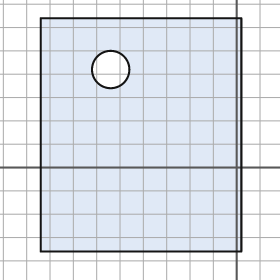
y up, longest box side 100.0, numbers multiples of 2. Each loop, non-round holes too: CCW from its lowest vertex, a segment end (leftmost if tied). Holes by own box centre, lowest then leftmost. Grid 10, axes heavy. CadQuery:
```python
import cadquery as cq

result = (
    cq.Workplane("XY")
    .moveTo(-84.0, -36.0)
    .lineTo(2.0, -36.0)
    .lineTo(2.0, 64.0)
    .lineTo(-84.0, 64.0)
    .close()
    .moveTo(-54.0, 42.0)
    .circle(8.0)
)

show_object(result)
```